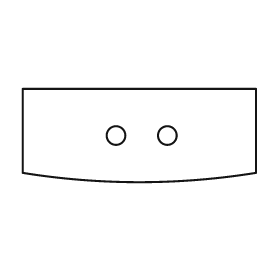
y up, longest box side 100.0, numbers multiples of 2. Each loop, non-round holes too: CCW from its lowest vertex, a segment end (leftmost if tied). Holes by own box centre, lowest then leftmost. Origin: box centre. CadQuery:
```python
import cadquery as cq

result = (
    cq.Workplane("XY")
    .moveTo(-50.0, -16.0)
    .threePointArc((0.0, -20.0), (50.0, -16.0))
    .lineTo(50.0, 20.0)
    .lineTo(-50.0, 20.0)
    .close()
    .moveTo(-10.0, 0.0)
    .circle(4.0)
    .moveTo(12.0, 0.0)
    .circle(4.0)
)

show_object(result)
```